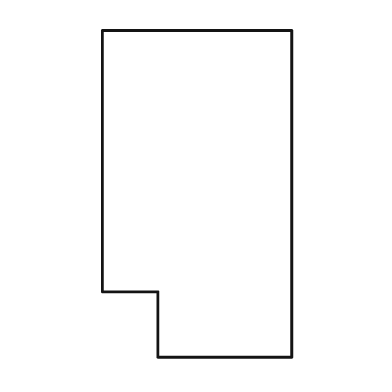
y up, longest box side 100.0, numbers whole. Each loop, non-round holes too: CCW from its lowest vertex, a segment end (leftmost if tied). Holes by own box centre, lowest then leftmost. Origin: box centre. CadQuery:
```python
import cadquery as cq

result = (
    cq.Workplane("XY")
    .moveTo(-12.0, -50.0)
    .lineTo(29.0, -50.0)
    .lineTo(29.0, 50.0)
    .lineTo(-29.0, 50.0)
    .lineTo(-29.0, -30.0)
    .lineTo(-12.0, -30.0)
    .close()
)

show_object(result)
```